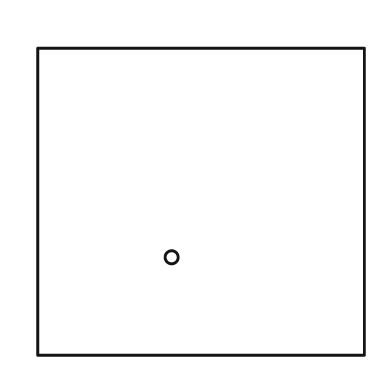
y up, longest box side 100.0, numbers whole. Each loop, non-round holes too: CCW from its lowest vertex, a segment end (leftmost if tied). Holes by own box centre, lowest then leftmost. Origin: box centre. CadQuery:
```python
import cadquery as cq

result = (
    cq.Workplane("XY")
    .moveTo(-50.0, -47.0)
    .lineTo(50.0, -47.0)
    .lineTo(50.0, 47.0)
    .lineTo(-50.0, 47.0)
    .close()
    .moveTo(-9.0, -17.0)
    .circle(2.0)
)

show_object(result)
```